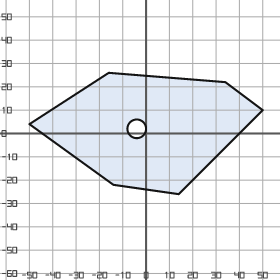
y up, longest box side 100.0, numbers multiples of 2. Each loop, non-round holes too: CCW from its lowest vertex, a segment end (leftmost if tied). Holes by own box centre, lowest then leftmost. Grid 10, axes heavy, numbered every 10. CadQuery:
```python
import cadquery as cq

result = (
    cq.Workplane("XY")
    .moveTo(14.0, -26.0)
    .lineTo(50.0, 10.0)
    .lineTo(34.0, 22.0)
    .lineTo(-16.0, 26.0)
    .lineTo(-50.0, 4.0)
    .lineTo(-14.0, -22.0)
    .close()
    .moveTo(-4.0, 2.0)
    .circle(4.0)
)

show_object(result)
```